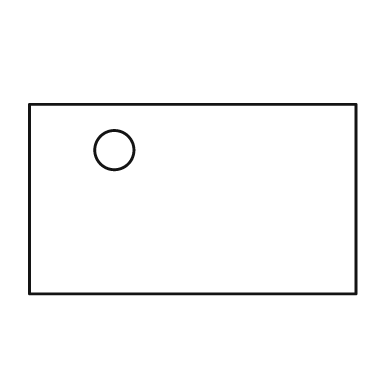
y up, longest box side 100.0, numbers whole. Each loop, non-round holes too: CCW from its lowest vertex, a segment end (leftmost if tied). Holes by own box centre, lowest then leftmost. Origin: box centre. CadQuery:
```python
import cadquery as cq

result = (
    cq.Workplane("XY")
    .moveTo(-50.0, -29.0)
    .lineTo(50.0, -29.0)
    .lineTo(50.0, 29.0)
    .lineTo(-50.0, 29.0)
    .close()
    .moveTo(-24.0, 15.0)
    .circle(6.0)
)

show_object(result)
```